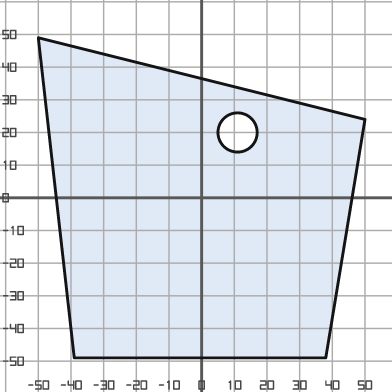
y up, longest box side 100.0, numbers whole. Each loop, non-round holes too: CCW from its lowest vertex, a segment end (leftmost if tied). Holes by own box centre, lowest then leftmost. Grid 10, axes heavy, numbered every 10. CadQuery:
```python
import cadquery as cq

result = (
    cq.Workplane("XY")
    .moveTo(-39.0, -49.0)
    .lineTo(38.0, -49.0)
    .lineTo(50.0, 24.0)
    .lineTo(-50.0, 49.0)
    .close()
    .moveTo(11.0, 20.0)
    .circle(6.0)
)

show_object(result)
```